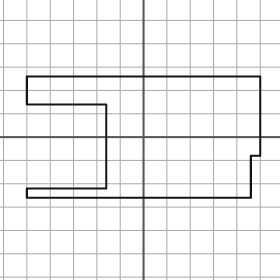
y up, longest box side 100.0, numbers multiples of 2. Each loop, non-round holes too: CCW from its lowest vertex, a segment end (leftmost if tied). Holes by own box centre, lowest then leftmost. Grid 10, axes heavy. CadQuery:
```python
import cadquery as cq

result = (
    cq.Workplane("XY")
    .moveTo(-50.0, -26.0)
    .lineTo(46.0, -26.0)
    .lineTo(46.0, -8.0)
    .lineTo(50.0, -8.0)
    .lineTo(50.0, 26.0)
    .lineTo(-50.0, 26.0)
    .lineTo(-50.0, 14.0)
    .lineTo(-16.0, 14.0)
    .lineTo(-16.0, -22.0)
    .lineTo(-50.0, -22.0)
    .close()
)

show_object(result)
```